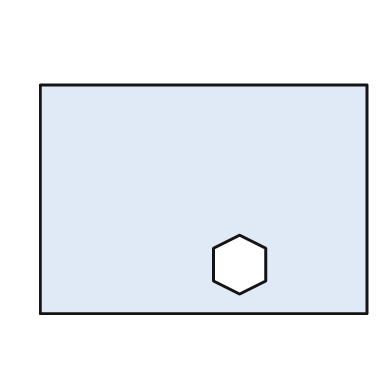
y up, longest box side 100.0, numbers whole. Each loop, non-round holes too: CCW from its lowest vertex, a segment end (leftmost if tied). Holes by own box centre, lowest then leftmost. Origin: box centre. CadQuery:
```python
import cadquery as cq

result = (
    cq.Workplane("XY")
    .moveTo(-50.0, -35.0)
    .lineTo(50.0, -35.0)
    .lineTo(50.0, 35.0)
    .lineTo(-50.0, 35.0)
    .close()
    .moveTo(11.0, -29.0)
    .lineTo(19.0, -25.0)
    .lineTo(19.0, -15.0)
    .lineTo(11.0, -11.0)
    .lineTo(3.0, -15.0)
    .lineTo(3.0, -25.0)
    .close()
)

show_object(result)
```